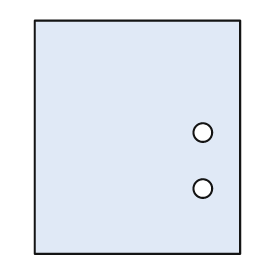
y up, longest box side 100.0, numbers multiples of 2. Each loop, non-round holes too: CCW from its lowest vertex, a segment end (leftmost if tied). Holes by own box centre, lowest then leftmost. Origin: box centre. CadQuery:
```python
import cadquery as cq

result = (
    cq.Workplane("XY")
    .moveTo(-44.0, -50.0)
    .lineTo(44.0, -50.0)
    .lineTo(44.0, 50.0)
    .lineTo(-44.0, 50.0)
    .close()
    .moveTo(28.0, -22.0)
    .circle(4.0)
    .moveTo(28.0, 2.0)
    .circle(4.0)
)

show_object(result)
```